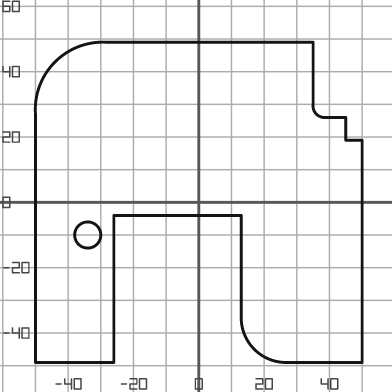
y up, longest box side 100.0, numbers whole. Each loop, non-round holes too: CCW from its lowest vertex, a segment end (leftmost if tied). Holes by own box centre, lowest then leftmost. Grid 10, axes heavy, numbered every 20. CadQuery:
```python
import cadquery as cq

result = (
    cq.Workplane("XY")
    .moveTo(-50.0, -49.0)
    .lineTo(-26.0, -49.0)
    .lineTo(-26.0, -4.0)
    .lineTo(13.0, -4.0)
    .lineTo(13.0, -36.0)
    .threePointArc((17.0, -45.0), (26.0, -49.0))
    .lineTo(50.0, -49.0)
    .lineTo(50.0, 19.0)
    .lineTo(45.0, 19.0)
    .lineTo(45.0, 26.0)
    .lineTo(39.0, 26.0)
    .threePointArc((36.0, 27.0), (35.0, 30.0))
    .lineTo(35.0, 49.0)
    .lineTo(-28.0, 49.0)
    .threePointArc((-44.0, 43.0), (-50.0, 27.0))
    .close()
    .moveTo(-34.0, -10.0)
    .circle(4.0)
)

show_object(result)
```